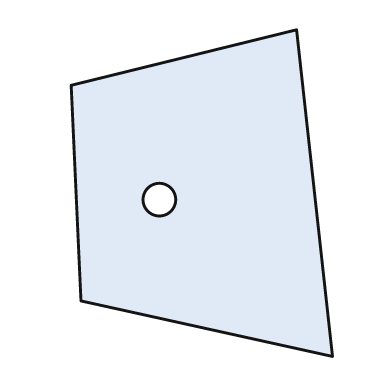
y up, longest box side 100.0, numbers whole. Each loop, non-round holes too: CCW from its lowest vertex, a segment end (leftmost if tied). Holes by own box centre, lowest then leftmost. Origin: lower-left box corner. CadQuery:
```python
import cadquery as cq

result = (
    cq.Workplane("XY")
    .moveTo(80.0, 0.0)
    .lineTo(69.0, 100.0)
    .lineTo(0.0, 83.0)
    .lineTo(3.0, 17.0)
    .close()
    .moveTo(27.0, 48.0)
    .circle(5.0)
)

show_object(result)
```